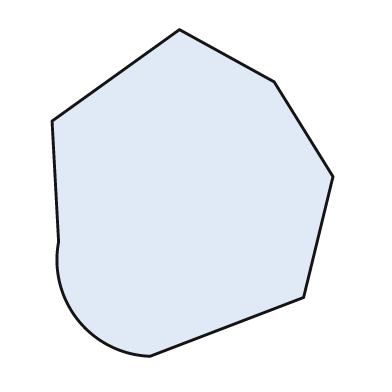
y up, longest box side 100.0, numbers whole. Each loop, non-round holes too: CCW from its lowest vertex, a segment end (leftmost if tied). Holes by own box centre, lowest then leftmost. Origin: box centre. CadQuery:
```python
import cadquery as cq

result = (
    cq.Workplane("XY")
    .moveTo(-13.0, -50.0)
    .lineTo(34.0, -32.0)
    .lineTo(43.0, 5.0)
    .lineTo(25.0, 34.0)
    .lineTo(-4.0, 50.0)
    .lineTo(-43.0, 22.0)
    .lineTo(-41.0, -15.0)
    .threePointArc((-35.0, -39.0), (-13.0, -50.0))
    .close()
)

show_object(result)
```